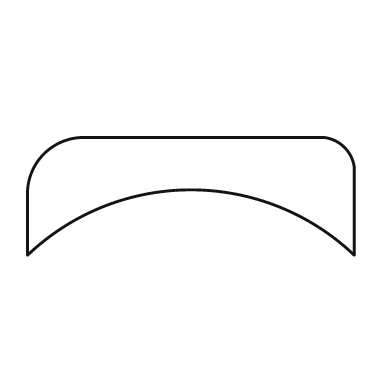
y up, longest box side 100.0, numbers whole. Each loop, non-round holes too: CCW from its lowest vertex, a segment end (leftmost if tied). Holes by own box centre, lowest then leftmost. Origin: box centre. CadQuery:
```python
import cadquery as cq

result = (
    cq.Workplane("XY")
    .moveTo(-50.0, -18.0)
    .threePointArc((0.0, 2.0), (50.0, -18.0))
    .lineTo(50.0, 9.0)
    .threePointArc((47.0, 15.0), (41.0, 18.0))
    .lineTo(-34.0, 18.0)
    .threePointArc((-45.0, 13.0), (-50.0, 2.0))
    .close()
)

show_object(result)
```